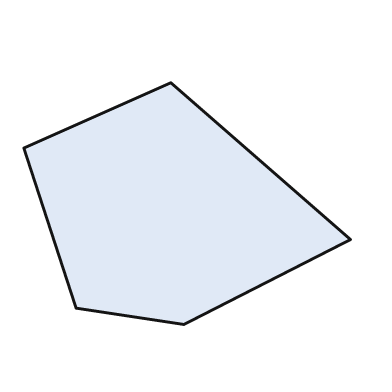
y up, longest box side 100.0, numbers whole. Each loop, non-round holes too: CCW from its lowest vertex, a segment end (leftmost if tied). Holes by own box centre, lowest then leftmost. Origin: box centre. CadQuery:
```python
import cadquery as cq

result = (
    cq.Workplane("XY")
    .moveTo(-1.0, -37.0)
    .lineTo(50.0, -11.0)
    .lineTo(-5.0, 37.0)
    .lineTo(-50.0, 17.0)
    .lineTo(-34.0, -32.0)
    .close()
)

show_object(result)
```